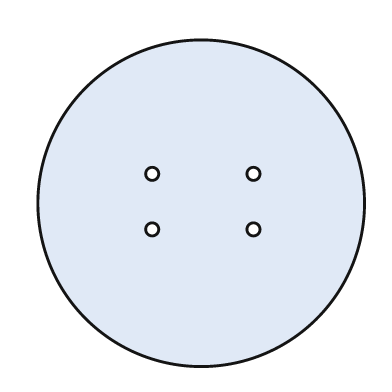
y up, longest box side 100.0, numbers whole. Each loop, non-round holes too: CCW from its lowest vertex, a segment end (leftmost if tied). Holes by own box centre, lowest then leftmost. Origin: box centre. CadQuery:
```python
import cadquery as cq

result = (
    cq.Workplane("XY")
    .moveTo(0.0, 0.0)
    .circle(50.0)
    .moveTo(-15.0, -8.0)
    .circle(2.0)
    .moveTo(16.0, -8.0)
    .circle(2.0)
    .moveTo(-15.0, 9.0)
    .circle(2.0)
    .moveTo(16.0, 9.0)
    .circle(2.0)
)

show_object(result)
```